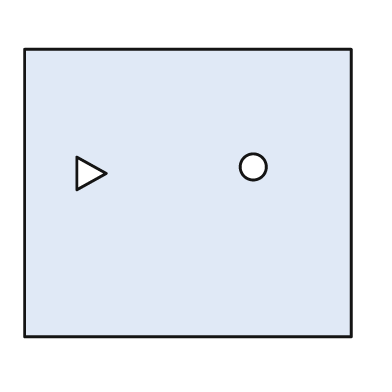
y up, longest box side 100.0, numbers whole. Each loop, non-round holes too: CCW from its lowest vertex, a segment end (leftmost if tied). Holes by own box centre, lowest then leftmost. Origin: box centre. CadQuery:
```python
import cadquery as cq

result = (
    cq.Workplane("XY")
    .moveTo(-50.0, -44.0)
    .lineTo(50.0, -44.0)
    .lineTo(50.0, 44.0)
    .lineTo(-50.0, 44.0)
    .close()
    .moveTo(-34.0, 1.0)
    .lineTo(-25.0, 6.0)
    .lineTo(-34.0, 11.0)
    .close()
    .moveTo(20.0, 8.0)
    .circle(4.0)
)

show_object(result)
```